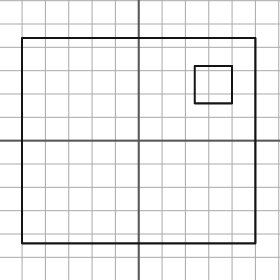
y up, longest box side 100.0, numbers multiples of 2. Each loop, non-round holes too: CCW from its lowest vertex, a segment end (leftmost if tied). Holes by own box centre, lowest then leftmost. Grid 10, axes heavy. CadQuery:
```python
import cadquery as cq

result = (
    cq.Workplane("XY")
    .moveTo(-50.0, -44.0)
    .lineTo(50.0, -44.0)
    .lineTo(50.0, 44.0)
    .lineTo(-50.0, 44.0)
    .close()
    .moveTo(24.0, 16.0)
    .lineTo(40.0, 16.0)
    .lineTo(40.0, 32.0)
    .lineTo(24.0, 32.0)
    .close()
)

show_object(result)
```